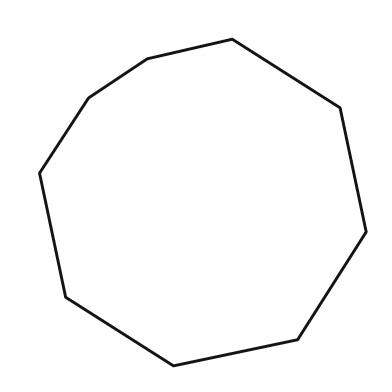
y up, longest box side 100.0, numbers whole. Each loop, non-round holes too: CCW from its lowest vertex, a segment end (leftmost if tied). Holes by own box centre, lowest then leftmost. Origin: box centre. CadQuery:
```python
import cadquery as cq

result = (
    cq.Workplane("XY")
    .moveTo(-9.0, -50.0)
    .lineTo(29.0, -42.0)
    .lineTo(50.0, -9.0)
    .lineTo(42.0, 29.0)
    .lineTo(9.0, 50.0)
    .lineTo(-17.0, 44.0)
    .lineTo(-35.0, 32.0)
    .lineTo(-50.0, 9.0)
    .lineTo(-42.0, -29.0)
    .close()
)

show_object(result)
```